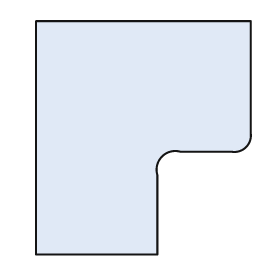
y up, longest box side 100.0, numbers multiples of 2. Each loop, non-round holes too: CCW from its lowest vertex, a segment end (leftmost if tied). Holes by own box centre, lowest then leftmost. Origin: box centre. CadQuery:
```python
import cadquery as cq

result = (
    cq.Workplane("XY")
    .moveTo(-46.0, -50.0)
    .lineTo(6.0, -50.0)
    .lineTo(6.0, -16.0)
    .threePointArc((8.0, -8.0), (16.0, -6.0))
    .lineTo(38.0, -6.0)
    .threePointArc((44.0, -4.0), (46.0, 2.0))
    .lineTo(46.0, 50.0)
    .lineTo(-46.0, 50.0)
    .close()
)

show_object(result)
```